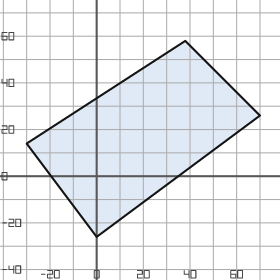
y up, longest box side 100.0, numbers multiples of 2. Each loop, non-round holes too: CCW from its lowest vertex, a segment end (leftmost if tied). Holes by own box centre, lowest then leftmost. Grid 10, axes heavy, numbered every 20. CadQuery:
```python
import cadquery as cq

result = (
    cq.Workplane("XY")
    .moveTo(0.0, -26.0)
    .lineTo(70.0, 26.0)
    .lineTo(38.0, 58.0)
    .lineTo(-30.0, 14.0)
    .close()
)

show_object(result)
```